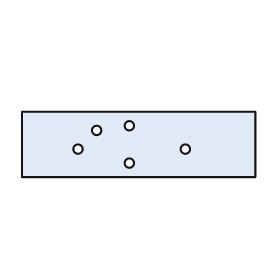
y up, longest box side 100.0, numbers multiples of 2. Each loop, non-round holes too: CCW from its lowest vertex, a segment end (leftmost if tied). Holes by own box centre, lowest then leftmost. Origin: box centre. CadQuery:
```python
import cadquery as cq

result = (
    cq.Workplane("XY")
    .moveTo(-50.0, -14.0)
    .lineTo(50.0, -14.0)
    .lineTo(50.0, 14.0)
    .lineTo(-50.0, 14.0)
    .close()
    .moveTo(-4.0, -8.0)
    .circle(2.0)
    .moveTo(-26.0, -2.0)
    .circle(2.0)
    .moveTo(20.0, -2.0)
    .circle(2.0)
    .moveTo(-18.0, 6.0)
    .circle(2.0)
    .moveTo(-4.0, 8.0)
    .circle(2.0)
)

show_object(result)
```